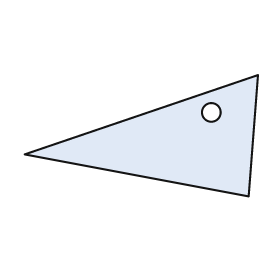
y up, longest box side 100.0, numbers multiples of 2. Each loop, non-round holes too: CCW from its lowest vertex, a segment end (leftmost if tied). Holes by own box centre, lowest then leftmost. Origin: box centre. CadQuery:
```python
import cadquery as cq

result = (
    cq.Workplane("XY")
    .moveTo(46.0, -26.0)
    .lineTo(50.0, 26.0)
    .lineTo(-50.0, -8.0)
    .close()
    .moveTo(30.0, 10.0)
    .circle(4.0)
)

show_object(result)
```